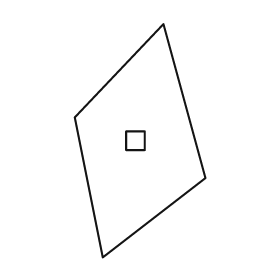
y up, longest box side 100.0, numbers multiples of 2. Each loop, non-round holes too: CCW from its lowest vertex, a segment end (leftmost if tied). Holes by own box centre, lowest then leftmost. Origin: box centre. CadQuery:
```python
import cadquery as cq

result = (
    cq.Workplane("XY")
    .moveTo(-16.0, -50.0)
    .lineTo(28.0, -16.0)
    .lineTo(10.0, 50.0)
    .lineTo(-28.0, 10.0)
    .close()
    .moveTo(-6.0, -4.0)
    .lineTo(2.0, -4.0)
    .lineTo(2.0, 4.0)
    .lineTo(-6.0, 4.0)
    .close()
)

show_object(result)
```